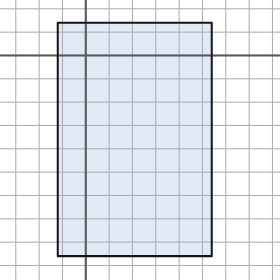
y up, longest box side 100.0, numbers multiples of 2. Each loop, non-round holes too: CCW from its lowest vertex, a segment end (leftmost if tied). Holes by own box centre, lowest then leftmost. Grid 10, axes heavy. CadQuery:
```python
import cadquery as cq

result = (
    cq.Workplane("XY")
    .moveTo(-12.0, -86.0)
    .lineTo(54.0, -86.0)
    .lineTo(54.0, 14.0)
    .lineTo(-12.0, 14.0)
    .close()
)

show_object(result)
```